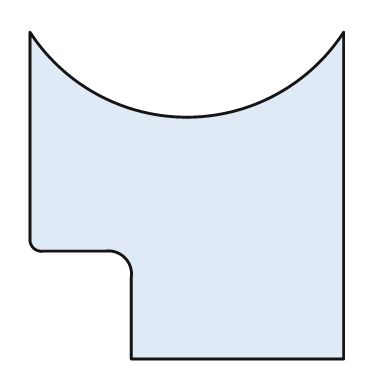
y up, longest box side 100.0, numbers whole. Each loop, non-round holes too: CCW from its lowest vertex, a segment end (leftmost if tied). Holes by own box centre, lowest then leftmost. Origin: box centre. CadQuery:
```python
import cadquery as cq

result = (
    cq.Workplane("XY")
    .moveTo(-17.0, -50.0)
    .lineTo(48.0, -50.0)
    .lineTo(48.0, 50.0)
    .threePointArc((0.0, 24.0), (-48.0, 50.0))
    .lineTo(-48.0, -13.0)
    .threePointArc((-47.0, -16.0), (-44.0, -17.0))
    .lineTo(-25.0, -17.0)
    .threePointArc((-19.0, -19.0), (-17.0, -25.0))
    .close()
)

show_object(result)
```